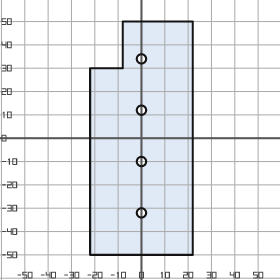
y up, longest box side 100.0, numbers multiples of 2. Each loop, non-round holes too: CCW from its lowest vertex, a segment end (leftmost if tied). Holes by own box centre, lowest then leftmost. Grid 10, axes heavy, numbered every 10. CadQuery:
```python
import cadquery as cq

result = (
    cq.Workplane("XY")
    .moveTo(-22.0, -50.0)
    .lineTo(22.0, -50.0)
    .lineTo(22.0, 50.0)
    .lineTo(-8.0, 50.0)
    .lineTo(-8.0, 30.0)
    .lineTo(-22.0, 30.0)
    .close()
    .moveTo(0.0, -32.0)
    .circle(2.0)
    .moveTo(0.0, -10.0)
    .circle(2.0)
    .moveTo(0.0, 12.0)
    .circle(2.0)
    .moveTo(0.0, 34.0)
    .circle(2.0)
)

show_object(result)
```